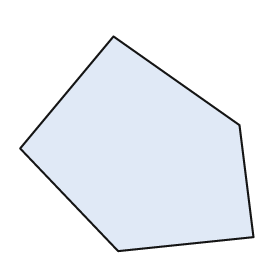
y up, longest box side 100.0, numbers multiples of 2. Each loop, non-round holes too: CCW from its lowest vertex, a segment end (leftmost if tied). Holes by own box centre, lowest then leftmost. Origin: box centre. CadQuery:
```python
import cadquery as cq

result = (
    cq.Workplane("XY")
    .moveTo(-8.0, -46.0)
    .lineTo(50.0, -40.0)
    .lineTo(44.0, 8.0)
    .lineTo(-10.0, 46.0)
    .lineTo(-50.0, -2.0)
    .close()
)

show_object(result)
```